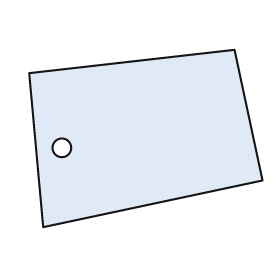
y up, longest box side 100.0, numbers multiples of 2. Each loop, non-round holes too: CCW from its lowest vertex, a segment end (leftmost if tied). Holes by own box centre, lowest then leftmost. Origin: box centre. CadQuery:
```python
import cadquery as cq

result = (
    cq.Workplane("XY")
    .moveTo(-44.0, -38.0)
    .lineTo(50.0, -18.0)
    .lineTo(38.0, 38.0)
    .lineTo(-50.0, 28.0)
    .close()
    .moveTo(-36.0, -4.0)
    .circle(4.0)
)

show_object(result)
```